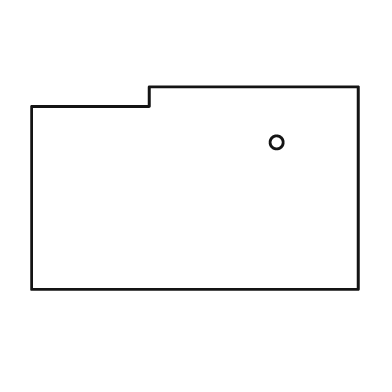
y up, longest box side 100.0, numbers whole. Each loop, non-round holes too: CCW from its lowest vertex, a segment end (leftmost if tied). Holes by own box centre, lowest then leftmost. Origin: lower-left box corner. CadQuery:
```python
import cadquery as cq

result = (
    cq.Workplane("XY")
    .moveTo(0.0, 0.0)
    .lineTo(100.0, 0.0)
    .lineTo(100.0, 62.0)
    .lineTo(36.0, 62.0)
    .lineTo(36.0, 56.0)
    .lineTo(0.0, 56.0)
    .close()
    .moveTo(75.0, 45.0)
    .circle(2.0)
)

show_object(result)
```